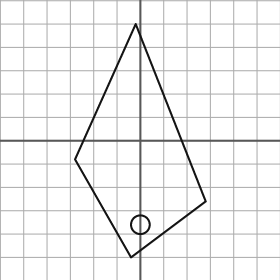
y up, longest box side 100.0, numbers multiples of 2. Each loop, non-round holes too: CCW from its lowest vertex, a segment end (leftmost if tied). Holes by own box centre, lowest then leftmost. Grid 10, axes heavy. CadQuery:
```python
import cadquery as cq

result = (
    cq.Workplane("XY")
    .moveTo(-4.0, -50.0)
    .lineTo(28.0, -26.0)
    .lineTo(-2.0, 50.0)
    .lineTo(-28.0, -8.0)
    .close()
    .moveTo(0.0, -36.0)
    .circle(4.0)
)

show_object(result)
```